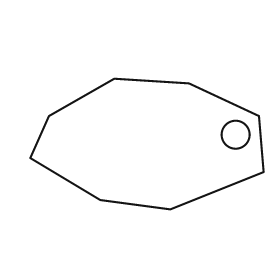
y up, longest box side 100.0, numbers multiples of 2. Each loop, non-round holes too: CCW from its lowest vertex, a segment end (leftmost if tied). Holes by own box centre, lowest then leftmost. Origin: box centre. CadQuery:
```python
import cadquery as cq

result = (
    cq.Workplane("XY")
    .moveTo(10.0, -28.0)
    .lineTo(50.0, -12.0)
    .lineTo(48.0, 12.0)
    .lineTo(18.0, 26.0)
    .lineTo(-14.0, 28.0)
    .lineTo(-42.0, 12.0)
    .lineTo(-50.0, -6.0)
    .lineTo(-20.0, -24.0)
    .close()
    .moveTo(38.0, 4.0)
    .circle(6.0)
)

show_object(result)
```